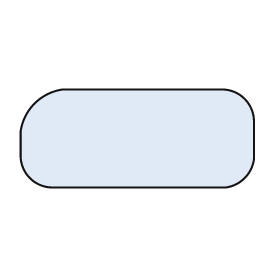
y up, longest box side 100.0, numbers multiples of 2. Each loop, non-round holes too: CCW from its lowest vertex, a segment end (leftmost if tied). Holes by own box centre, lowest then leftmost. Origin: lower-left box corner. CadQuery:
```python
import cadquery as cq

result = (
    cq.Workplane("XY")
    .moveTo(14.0, 0.0)
    .lineTo(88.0, 0.0)
    .threePointArc((96.0, 4.0), (100.0, 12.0))
    .lineTo(100.0, 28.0)
    .threePointArc((96.0, 38.0), (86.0, 42.0))
    .lineTo(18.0, 42.0)
    .threePointArc((6.0, 36.0), (0.0, 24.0))
    .lineTo(0.0, 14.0)
    .threePointArc((4.0, 4.0), (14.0, 0.0))
    .close()
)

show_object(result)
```